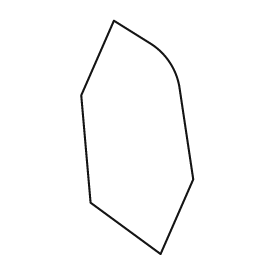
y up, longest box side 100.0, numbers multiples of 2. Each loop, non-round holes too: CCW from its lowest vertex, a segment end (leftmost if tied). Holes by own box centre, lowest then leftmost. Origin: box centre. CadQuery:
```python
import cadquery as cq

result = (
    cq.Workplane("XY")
    .moveTo(10.0, -50.0)
    .lineTo(24.0, -18.0)
    .lineTo(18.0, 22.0)
    .threePointArc((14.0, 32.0), (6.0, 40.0))
    .lineTo(-10.0, 50.0)
    .lineTo(-24.0, 18.0)
    .lineTo(-20.0, -28.0)
    .close()
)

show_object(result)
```